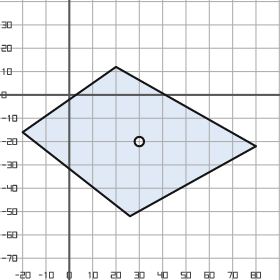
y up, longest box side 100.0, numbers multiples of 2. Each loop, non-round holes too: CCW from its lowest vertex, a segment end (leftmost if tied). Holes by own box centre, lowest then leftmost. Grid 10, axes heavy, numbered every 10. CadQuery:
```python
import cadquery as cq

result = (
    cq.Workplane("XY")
    .moveTo(26.0, -52.0)
    .lineTo(80.0, -22.0)
    .lineTo(20.0, 12.0)
    .lineTo(-20.0, -16.0)
    .close()
    .moveTo(30.0, -20.0)
    .circle(2.0)
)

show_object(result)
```